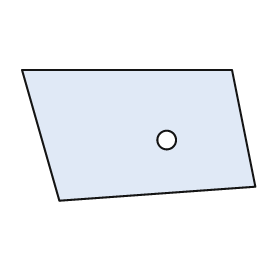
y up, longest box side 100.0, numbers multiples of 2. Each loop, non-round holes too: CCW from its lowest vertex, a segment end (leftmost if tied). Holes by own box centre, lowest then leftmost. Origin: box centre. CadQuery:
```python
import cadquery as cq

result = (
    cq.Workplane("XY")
    .moveTo(-34.0, -28.0)
    .lineTo(50.0, -22.0)
    .lineTo(40.0, 28.0)
    .lineTo(-50.0, 28.0)
    .close()
    .moveTo(12.0, -2.0)
    .circle(4.0)
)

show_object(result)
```